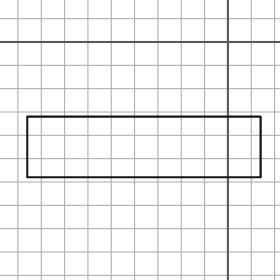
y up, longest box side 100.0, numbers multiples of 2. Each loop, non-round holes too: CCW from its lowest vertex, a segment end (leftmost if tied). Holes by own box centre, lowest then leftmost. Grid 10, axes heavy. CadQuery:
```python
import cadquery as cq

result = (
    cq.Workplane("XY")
    .moveTo(-86.0, -58.0)
    .lineTo(14.0, -58.0)
    .lineTo(14.0, -32.0)
    .lineTo(-86.0, -32.0)
    .close()
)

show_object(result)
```